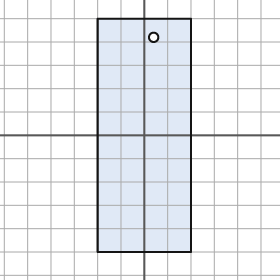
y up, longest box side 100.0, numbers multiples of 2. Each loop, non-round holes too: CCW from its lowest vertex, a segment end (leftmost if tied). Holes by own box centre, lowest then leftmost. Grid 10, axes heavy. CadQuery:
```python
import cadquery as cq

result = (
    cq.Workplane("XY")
    .moveTo(-20.0, -50.0)
    .lineTo(20.0, -50.0)
    .lineTo(20.0, 50.0)
    .lineTo(-20.0, 50.0)
    .close()
    .moveTo(4.0, 42.0)
    .circle(2.0)
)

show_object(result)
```